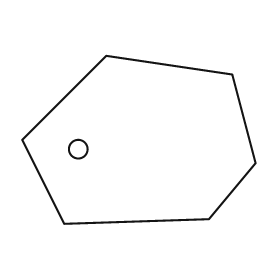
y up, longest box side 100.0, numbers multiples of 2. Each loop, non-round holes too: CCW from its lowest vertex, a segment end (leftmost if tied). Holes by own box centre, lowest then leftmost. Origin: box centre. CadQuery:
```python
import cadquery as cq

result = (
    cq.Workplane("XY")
    .moveTo(-32.0, -36.0)
    .lineTo(30.0, -34.0)
    .lineTo(50.0, -10.0)
    .lineTo(40.0, 28.0)
    .lineTo(-14.0, 36.0)
    .lineTo(-50.0, 0.0)
    .close()
    .moveTo(-26.0, -4.0)
    .circle(4.0)
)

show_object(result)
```